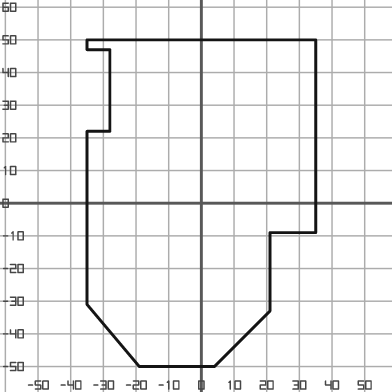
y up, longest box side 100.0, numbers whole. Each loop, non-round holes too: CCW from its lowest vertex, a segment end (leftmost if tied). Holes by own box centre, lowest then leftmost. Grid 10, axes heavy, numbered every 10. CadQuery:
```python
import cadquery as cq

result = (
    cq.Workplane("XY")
    .moveTo(-19.0, -50.0)
    .lineTo(4.0, -50.0)
    .lineTo(21.0, -33.0)
    .lineTo(21.0, -9.0)
    .lineTo(35.0, -9.0)
    .lineTo(35.0, 50.0)
    .lineTo(-35.0, 50.0)
    .lineTo(-35.0, 47.0)
    .lineTo(-28.0, 47.0)
    .lineTo(-28.0, 22.0)
    .lineTo(-35.0, 22.0)
    .lineTo(-35.0, -31.0)
    .close()
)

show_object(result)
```